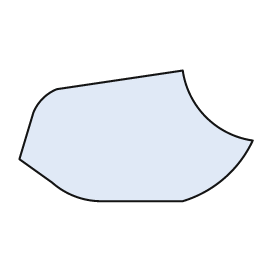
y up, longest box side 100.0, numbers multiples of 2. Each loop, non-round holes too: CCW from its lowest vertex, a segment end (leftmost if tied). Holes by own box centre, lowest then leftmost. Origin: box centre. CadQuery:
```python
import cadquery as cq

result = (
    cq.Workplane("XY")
    .moveTo(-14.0, -28.0)
    .lineTo(20.0, -28.0)
    .threePointArc((38.0, -18.0), (50.0, -2.0))
    .threePointArc((30.0, 8.0), (20.0, 28.0))
    .lineTo(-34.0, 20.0)
    .threePointArc((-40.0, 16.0), (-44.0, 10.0))
    .lineTo(-50.0, -10.0)
    .lineTo(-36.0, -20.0)
    .threePointArc((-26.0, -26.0), (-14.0, -28.0))
    .close()
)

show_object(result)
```